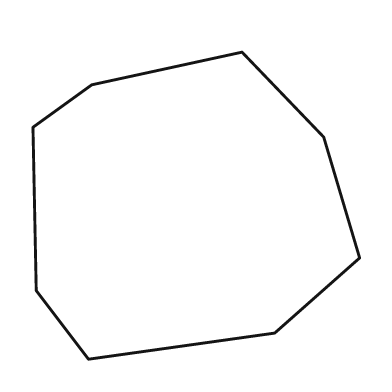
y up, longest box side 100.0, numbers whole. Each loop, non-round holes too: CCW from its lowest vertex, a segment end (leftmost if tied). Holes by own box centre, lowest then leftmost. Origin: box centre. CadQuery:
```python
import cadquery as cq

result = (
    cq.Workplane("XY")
    .moveTo(-33.0, -47.0)
    .lineTo(24.0, -39.0)
    .lineTo(50.0, -16.0)
    .lineTo(39.0, 21.0)
    .lineTo(14.0, 47.0)
    .lineTo(-32.0, 37.0)
    .lineTo(-50.0, 24.0)
    .lineTo(-49.0, -26.0)
    .close()
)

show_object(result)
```